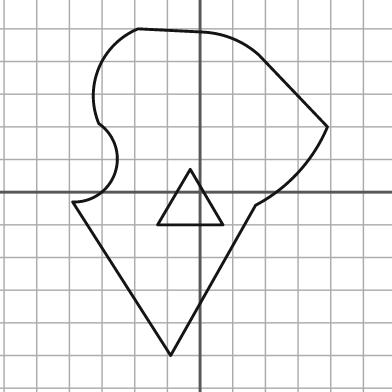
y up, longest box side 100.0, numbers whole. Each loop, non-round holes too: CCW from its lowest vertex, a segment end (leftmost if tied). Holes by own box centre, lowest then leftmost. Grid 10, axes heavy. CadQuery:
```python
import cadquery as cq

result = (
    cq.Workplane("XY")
    .moveTo(-9.0, -50.0)
    .lineTo(17.0, -4.0)
    .threePointArc((30.0, 6.0), (39.0, 20.0))
    .lineTo(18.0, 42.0)
    .threePointArc((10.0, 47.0), (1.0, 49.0))
    .lineTo(-19.0, 50.0)
    .threePointArc((-31.0, 38.0), (-31.0, 21.0))
    .threePointArc((-26.0, 6.0), (-39.0, -3.0))
    .close()
    .moveTo(-13.0, -10.0)
    .lineTo(7.0, -10.0)
    .lineTo(-3.0, 7.0)
    .close()
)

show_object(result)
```